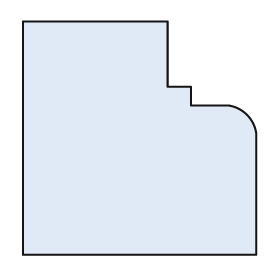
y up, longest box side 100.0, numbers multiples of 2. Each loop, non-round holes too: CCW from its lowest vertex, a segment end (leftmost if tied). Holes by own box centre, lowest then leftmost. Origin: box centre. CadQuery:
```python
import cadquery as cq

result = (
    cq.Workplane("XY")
    .moveTo(-50.0, -50.0)
    .lineTo(50.0, -50.0)
    .lineTo(50.0, 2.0)
    .threePointArc((46.0, 10.0), (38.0, 14.0))
    .lineTo(22.0, 14.0)
    .lineTo(22.0, 22.0)
    .lineTo(12.0, 22.0)
    .lineTo(12.0, 50.0)
    .lineTo(-50.0, 50.0)
    .close()
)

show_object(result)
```